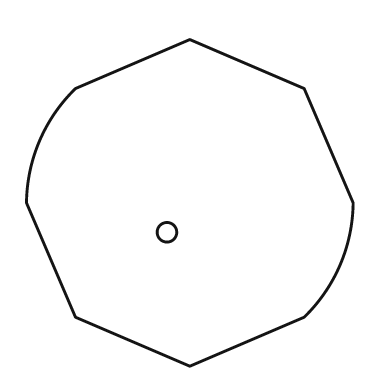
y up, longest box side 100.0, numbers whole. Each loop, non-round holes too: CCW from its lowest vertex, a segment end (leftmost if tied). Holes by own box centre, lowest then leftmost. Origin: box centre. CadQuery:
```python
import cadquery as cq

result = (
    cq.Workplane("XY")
    .moveTo(0.0, -50.0)
    .lineTo(35.0, -35.0)
    .threePointArc((46.0, -19.0), (50.0, 0.0))
    .lineTo(35.0, 35.0)
    .lineTo(0.0, 50.0)
    .lineTo(-35.0, 35.0)
    .threePointArc((-46.0, 19.0), (-50.0, 0.0))
    .lineTo(-35.0, -35.0)
    .close()
    .moveTo(-7.0, -9.0)
    .circle(3.0)
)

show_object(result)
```